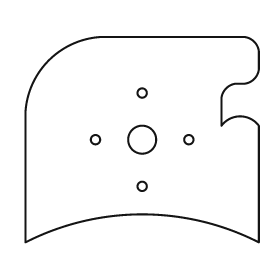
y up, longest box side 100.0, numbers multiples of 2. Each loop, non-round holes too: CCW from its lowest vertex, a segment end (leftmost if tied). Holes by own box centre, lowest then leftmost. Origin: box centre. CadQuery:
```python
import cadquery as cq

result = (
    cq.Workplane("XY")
    .moveTo(-50.0, -44.0)
    .threePointArc((0.0, -32.0), (50.0, -44.0))
    .lineTo(50.0, 6.0)
    .threePointArc((42.0, 10.0), (34.0, 6.0))
    .lineTo(34.0, 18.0)
    .threePointArc((36.0, 22.0), (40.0, 24.0))
    .lineTo(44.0, 24.0)
    .threePointArc((48.0, 26.0), (50.0, 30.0))
    .lineTo(50.0, 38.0)
    .threePointArc((48.0, 42.0), (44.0, 44.0))
    .lineTo(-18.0, 44.0)
    .threePointArc((-40.0, 34.0), (-50.0, 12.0))
    .close()
    .moveTo(0.0, -20.0)
    .circle(2.0)
    .moveTo(-20.0, 0.0)
    .circle(2.0)
    .moveTo(0.0, 0.0)
    .circle(6.0)
    .moveTo(20.0, 0.0)
    .circle(2.0)
    .moveTo(0.0, 20.0)
    .circle(2.0)
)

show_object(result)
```